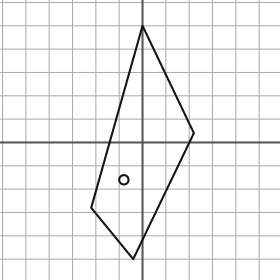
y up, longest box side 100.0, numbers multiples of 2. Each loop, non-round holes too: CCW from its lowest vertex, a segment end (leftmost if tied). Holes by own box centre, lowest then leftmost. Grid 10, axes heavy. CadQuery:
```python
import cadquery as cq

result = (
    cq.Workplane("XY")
    .moveTo(-4.0, -50.0)
    .lineTo(22.0, 4.0)
    .lineTo(0.0, 50.0)
    .lineTo(-22.0, -28.0)
    .close()
    .moveTo(-8.0, -16.0)
    .circle(2.0)
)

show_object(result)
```